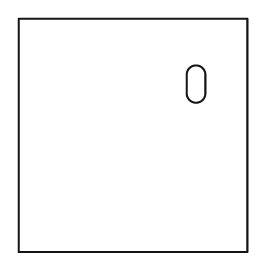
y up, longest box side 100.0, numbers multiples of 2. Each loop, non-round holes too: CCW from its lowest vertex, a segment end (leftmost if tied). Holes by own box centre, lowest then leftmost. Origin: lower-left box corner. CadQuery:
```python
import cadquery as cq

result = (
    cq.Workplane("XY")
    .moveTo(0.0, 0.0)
    .lineTo(98.0, 0.0)
    .lineTo(98.0, 100.0)
    .lineTo(0.0, 100.0)
    .close()
    .moveTo(72.0, 68.0)
    .threePointArc((76.0, 64.0), (80.0, 68.0))
    .lineTo(80.0, 76.0)
    .threePointArc((76.0, 80.0), (72.0, 76.0))
    .close()
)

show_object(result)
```